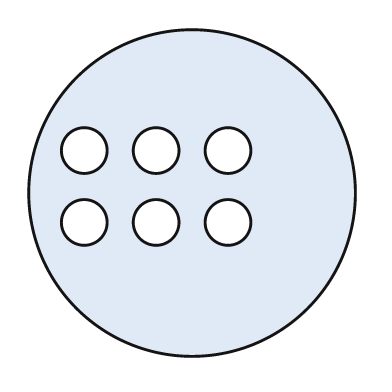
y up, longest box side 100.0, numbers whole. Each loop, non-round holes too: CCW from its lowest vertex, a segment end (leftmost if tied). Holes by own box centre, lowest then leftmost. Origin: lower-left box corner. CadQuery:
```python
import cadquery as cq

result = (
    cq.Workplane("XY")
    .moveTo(50.0, 50.0)
    .circle(50.0)
    .moveTo(17.0, 41.0)
    .circle(7.0)
    .moveTo(39.0, 41.0)
    .circle(7.0)
    .moveTo(61.0, 41.0)
    .circle(7.0)
    .moveTo(17.0, 63.0)
    .circle(7.0)
    .moveTo(39.0, 63.0)
    .circle(7.0)
    .moveTo(61.0, 63.0)
    .circle(7.0)
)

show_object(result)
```